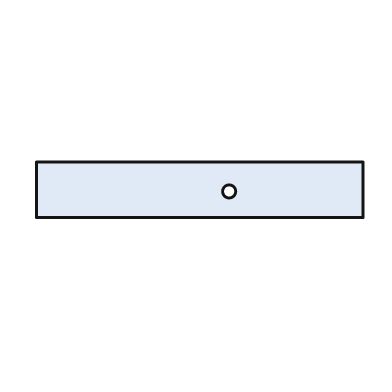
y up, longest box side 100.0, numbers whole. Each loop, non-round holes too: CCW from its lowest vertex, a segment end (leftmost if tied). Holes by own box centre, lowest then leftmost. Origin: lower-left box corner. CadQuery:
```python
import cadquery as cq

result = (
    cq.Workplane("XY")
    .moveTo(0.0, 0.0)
    .lineTo(100.0, 0.0)
    .lineTo(100.0, 17.0)
    .lineTo(0.0, 17.0)
    .close()
    .moveTo(59.0, 8.0)
    .circle(2.0)
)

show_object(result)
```